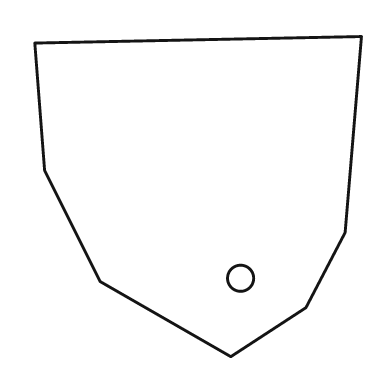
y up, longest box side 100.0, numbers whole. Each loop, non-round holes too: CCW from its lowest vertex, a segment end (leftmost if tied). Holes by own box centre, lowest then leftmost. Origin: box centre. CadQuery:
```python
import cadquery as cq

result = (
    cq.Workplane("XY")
    .moveTo(10.0, -49.0)
    .lineTo(33.0, -34.0)
    .lineTo(45.0, -11.0)
    .lineTo(50.0, 49.0)
    .lineTo(-50.0, 47.0)
    .lineTo(-47.0, 8.0)
    .lineTo(-30.0, -26.0)
    .close()
    .moveTo(13.0, -25.0)
    .circle(4.0)
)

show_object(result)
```